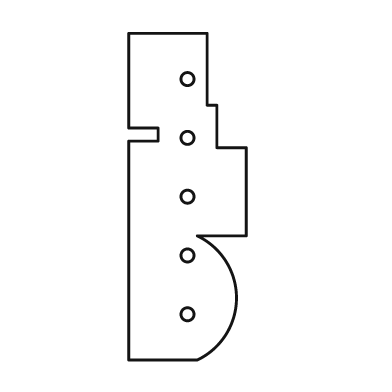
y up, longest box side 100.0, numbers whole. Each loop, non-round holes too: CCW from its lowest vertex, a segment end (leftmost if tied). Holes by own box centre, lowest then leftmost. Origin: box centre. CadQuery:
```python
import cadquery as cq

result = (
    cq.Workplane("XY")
    .moveTo(-18.0, -50.0)
    .lineTo(3.0, -50.0)
    .threePointArc((15.0, -31.0), (3.0, -12.0))
    .lineTo(18.0, -12.0)
    .lineTo(18.0, 15.0)
    .lineTo(9.0, 15.0)
    .lineTo(9.0, 28.0)
    .lineTo(6.0, 28.0)
    .lineTo(6.0, 50.0)
    .lineTo(-18.0, 50.0)
    .lineTo(-18.0, 21.0)
    .lineTo(-9.0, 21.0)
    .lineTo(-9.0, 17.0)
    .lineTo(-18.0, 17.0)
    .close()
    .moveTo(0.0, -36.0)
    .circle(2.0)
    .moveTo(0.0, -18.0)
    .circle(2.0)
    .moveTo(0.0, 0.0)
    .circle(2.0)
    .moveTo(0.0, 18.0)
    .circle(2.0)
    .moveTo(0.0, 36.0)
    .circle(2.0)
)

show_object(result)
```